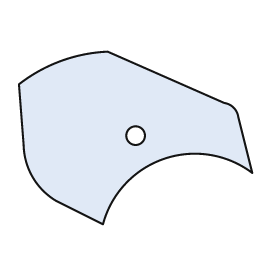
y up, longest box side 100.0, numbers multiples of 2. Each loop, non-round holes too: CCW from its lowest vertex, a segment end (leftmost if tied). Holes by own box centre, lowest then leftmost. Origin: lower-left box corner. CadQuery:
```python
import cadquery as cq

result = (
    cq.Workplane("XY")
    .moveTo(36.0, 0.0)
    .threePointArc((62.0, 28.0), (100.0, 22.0))
    .lineTo(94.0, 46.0)
    .threePointArc((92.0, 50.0), (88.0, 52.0))
    .lineTo(38.0, 74.0)
    .threePointArc((18.0, 70.0), (0.0, 60.0))
    .lineTo(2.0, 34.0)
    .threePointArc((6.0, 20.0), (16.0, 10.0))
    .close()
    .moveTo(50.0, 38.0)
    .circle(4.0)
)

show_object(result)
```